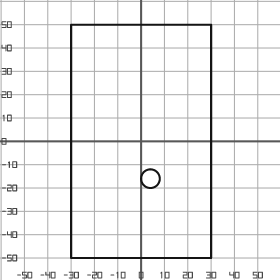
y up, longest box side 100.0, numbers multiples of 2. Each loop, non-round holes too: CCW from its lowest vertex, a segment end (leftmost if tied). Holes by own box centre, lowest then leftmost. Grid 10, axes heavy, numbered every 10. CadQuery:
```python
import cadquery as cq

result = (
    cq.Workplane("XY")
    .moveTo(-30.0, -50.0)
    .lineTo(30.0, -50.0)
    .lineTo(30.0, 50.0)
    .lineTo(-30.0, 50.0)
    .close()
    .moveTo(4.0, -16.0)
    .circle(4.0)
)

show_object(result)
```